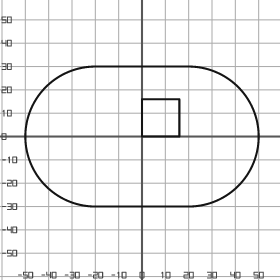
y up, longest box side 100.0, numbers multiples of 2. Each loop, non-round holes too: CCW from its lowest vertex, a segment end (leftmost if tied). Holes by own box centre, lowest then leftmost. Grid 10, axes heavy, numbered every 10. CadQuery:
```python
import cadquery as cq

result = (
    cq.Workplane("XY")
    .moveTo(-20.0, -30.0)
    .lineTo(20.0, -30.0)
    .threePointArc((50.0, 0.0), (20.0, 30.0))
    .lineTo(-20.0, 30.0)
    .threePointArc((-50.0, 0.0), (-20.0, -30.0))
    .close()
    .moveTo(0.0, 0.0)
    .lineTo(16.0, 0.0)
    .lineTo(16.0, 16.0)
    .lineTo(0.0, 16.0)
    .close()
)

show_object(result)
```